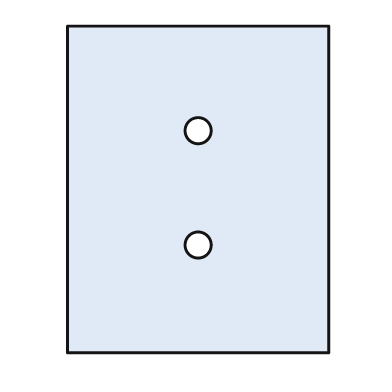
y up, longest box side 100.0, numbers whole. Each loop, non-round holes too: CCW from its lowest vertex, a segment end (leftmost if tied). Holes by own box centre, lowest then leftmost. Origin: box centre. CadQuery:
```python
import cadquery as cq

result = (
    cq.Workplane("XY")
    .moveTo(-40.0, -50.0)
    .lineTo(40.0, -50.0)
    .lineTo(40.0, 50.0)
    .lineTo(-40.0, 50.0)
    .close()
    .moveTo(0.0, -17.0)
    .circle(4.0)
    .moveTo(0.0, 18.0)
    .circle(4.0)
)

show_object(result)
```